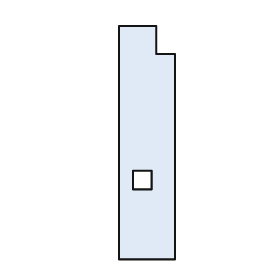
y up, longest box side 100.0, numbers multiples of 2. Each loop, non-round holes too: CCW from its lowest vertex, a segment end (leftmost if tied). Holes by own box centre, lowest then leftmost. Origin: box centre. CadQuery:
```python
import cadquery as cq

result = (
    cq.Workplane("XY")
    .moveTo(-12.0, -50.0)
    .lineTo(12.0, -50.0)
    .lineTo(12.0, 38.0)
    .lineTo(4.0, 38.0)
    .lineTo(4.0, 50.0)
    .lineTo(-12.0, 50.0)
    .close()
    .moveTo(-6.0, -20.0)
    .lineTo(2.0, -20.0)
    .lineTo(2.0, -12.0)
    .lineTo(-6.0, -12.0)
    .close()
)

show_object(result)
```